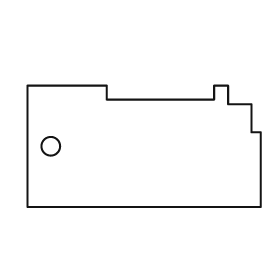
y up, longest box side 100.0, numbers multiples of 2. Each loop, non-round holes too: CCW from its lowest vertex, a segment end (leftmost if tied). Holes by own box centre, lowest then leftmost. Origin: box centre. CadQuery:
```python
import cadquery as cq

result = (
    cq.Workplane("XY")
    .moveTo(-50.0, -26.0)
    .lineTo(50.0, -26.0)
    .lineTo(50.0, 6.0)
    .lineTo(46.0, 6.0)
    .lineTo(46.0, 18.0)
    .lineTo(36.0, 18.0)
    .lineTo(36.0, 26.0)
    .lineTo(30.0, 26.0)
    .lineTo(30.0, 20.0)
    .lineTo(-16.0, 20.0)
    .lineTo(-16.0, 26.0)
    .lineTo(-50.0, 26.0)
    .close()
    .moveTo(-40.0, 0.0)
    .circle(4.0)
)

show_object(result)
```